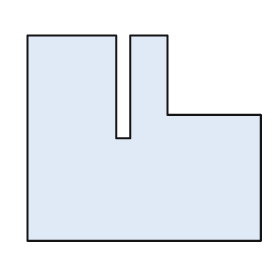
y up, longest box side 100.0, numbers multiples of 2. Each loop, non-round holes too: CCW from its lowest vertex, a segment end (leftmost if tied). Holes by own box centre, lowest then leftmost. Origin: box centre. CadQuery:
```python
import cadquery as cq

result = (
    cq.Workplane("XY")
    .moveTo(-50.0, -44.0)
    .lineTo(50.0, -44.0)
    .lineTo(50.0, 10.0)
    .lineTo(10.0, 10.0)
    .lineTo(10.0, 44.0)
    .lineTo(-6.0, 44.0)
    .lineTo(-6.0, 0.0)
    .lineTo(-12.0, 0.0)
    .lineTo(-12.0, 44.0)
    .lineTo(-50.0, 44.0)
    .close()
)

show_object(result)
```